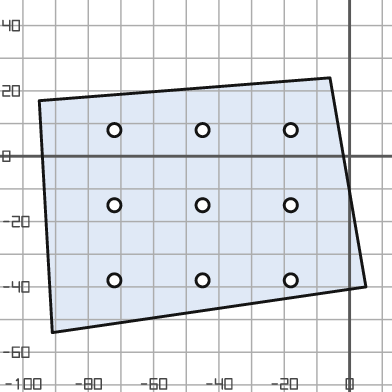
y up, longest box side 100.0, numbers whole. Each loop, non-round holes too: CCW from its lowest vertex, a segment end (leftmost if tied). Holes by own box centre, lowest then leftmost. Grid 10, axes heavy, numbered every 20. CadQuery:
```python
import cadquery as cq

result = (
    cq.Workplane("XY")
    .moveTo(-91.0, -54.0)
    .lineTo(5.0, -40.0)
    .lineTo(-6.0, 24.0)
    .lineTo(-95.0, 17.0)
    .close()
    .moveTo(-72.0, -38.0)
    .circle(2.0)
    .moveTo(-45.0, -38.0)
    .circle(2.0)
    .moveTo(-18.0, -38.0)
    .circle(2.0)
    .moveTo(-72.0, -15.0)
    .circle(2.0)
    .moveTo(-45.0, -15.0)
    .circle(2.0)
    .moveTo(-18.0, -15.0)
    .circle(2.0)
    .moveTo(-72.0, 8.0)
    .circle(2.0)
    .moveTo(-45.0, 8.0)
    .circle(2.0)
    .moveTo(-18.0, 8.0)
    .circle(2.0)
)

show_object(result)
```